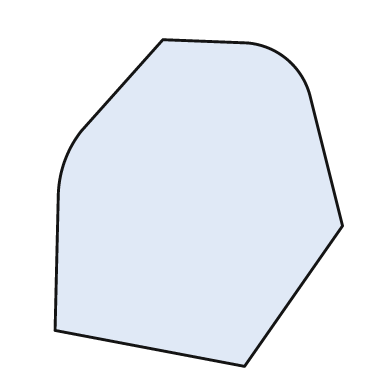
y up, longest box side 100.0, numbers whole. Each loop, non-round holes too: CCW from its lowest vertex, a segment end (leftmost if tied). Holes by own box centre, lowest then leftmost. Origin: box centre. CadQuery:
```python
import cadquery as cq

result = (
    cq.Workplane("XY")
    .moveTo(14.0, -50.0)
    .lineTo(44.0, -7.0)
    .lineTo(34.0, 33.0)
    .threePointArc((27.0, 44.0), (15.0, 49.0))
    .lineTo(-11.0, 50.0)
    .lineTo(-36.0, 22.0)
    .threePointArc((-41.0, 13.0), (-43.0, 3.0))
    .lineTo(-44.0, -39.0)
    .close()
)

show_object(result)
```